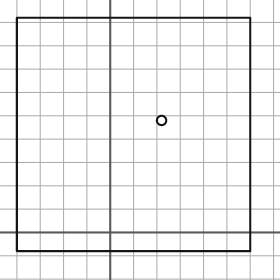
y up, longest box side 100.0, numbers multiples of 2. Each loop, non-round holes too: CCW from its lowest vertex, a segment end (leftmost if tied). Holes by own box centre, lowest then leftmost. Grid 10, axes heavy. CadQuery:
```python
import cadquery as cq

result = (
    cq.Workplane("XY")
    .moveTo(-40.0, -8.0)
    .lineTo(60.0, -8.0)
    .lineTo(60.0, 92.0)
    .lineTo(-40.0, 92.0)
    .close()
    .moveTo(22.0, 48.0)
    .circle(2.0)
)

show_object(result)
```